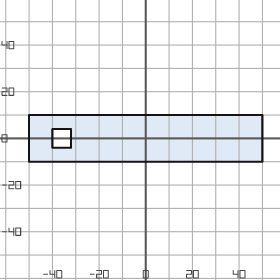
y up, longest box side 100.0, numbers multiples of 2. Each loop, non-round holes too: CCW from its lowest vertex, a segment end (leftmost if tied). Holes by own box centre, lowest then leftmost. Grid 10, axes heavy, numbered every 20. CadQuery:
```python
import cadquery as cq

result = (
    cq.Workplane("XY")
    .moveTo(-50.0, -10.0)
    .lineTo(50.0, -10.0)
    .lineTo(50.0, 10.0)
    .lineTo(-50.0, 10.0)
    .close()
    .moveTo(-40.0, -4.0)
    .lineTo(-32.0, -4.0)
    .lineTo(-32.0, 4.0)
    .lineTo(-40.0, 4.0)
    .close()
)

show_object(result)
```